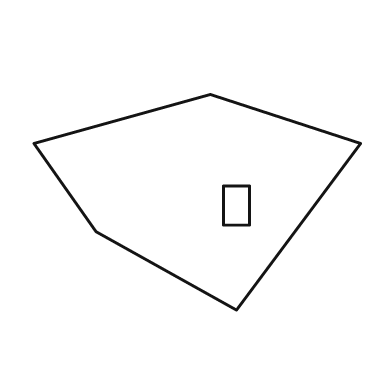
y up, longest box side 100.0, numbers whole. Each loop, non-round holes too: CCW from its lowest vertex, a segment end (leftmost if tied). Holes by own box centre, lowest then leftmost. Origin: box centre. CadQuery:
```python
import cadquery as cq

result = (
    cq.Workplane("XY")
    .moveTo(12.0, -33.0)
    .lineTo(50.0, 18.0)
    .lineTo(4.0, 33.0)
    .lineTo(-50.0, 18.0)
    .lineTo(-31.0, -9.0)
    .close()
    .moveTo(8.0, -7.0)
    .lineTo(16.0, -7.0)
    .lineTo(16.0, 5.0)
    .lineTo(8.0, 5.0)
    .close()
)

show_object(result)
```